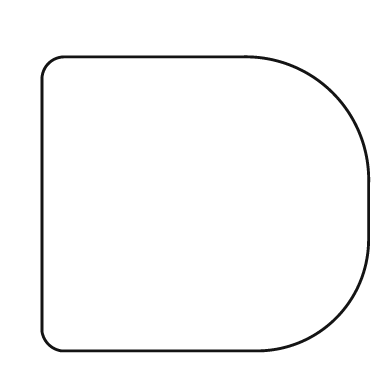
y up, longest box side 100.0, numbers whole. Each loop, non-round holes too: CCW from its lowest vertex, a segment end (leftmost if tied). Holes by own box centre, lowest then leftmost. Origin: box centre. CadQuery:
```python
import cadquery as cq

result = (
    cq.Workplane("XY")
    .moveTo(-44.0, -45.0)
    .lineTo(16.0, -45.0)
    .threePointArc((40.0, -35.0), (50.0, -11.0))
    .lineTo(50.0, 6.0)
    .threePointArc((39.0, 34.0), (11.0, 45.0))
    .lineTo(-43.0, 45.0)
    .threePointArc((-48.0, 43.0), (-50.0, 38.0))
    .lineTo(-50.0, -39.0)
    .threePointArc((-48.0, -43.0), (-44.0, -45.0))
    .close()
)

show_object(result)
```